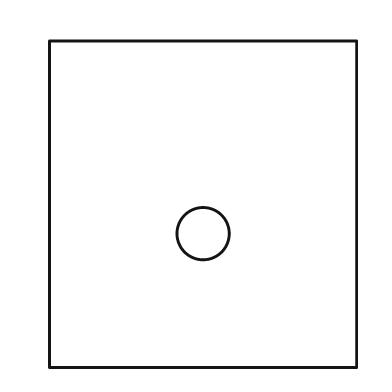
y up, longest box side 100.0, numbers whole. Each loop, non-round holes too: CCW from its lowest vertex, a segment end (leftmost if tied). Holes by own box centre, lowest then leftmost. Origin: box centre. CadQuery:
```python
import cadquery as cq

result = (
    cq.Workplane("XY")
    .moveTo(-47.0, -50.0)
    .lineTo(47.0, -50.0)
    .lineTo(47.0, 50.0)
    .lineTo(-47.0, 50.0)
    .close()
    .moveTo(0.0, -9.0)
    .circle(8.0)
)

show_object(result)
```